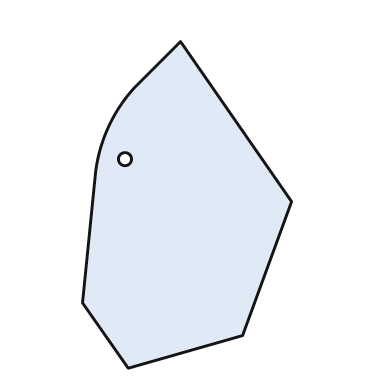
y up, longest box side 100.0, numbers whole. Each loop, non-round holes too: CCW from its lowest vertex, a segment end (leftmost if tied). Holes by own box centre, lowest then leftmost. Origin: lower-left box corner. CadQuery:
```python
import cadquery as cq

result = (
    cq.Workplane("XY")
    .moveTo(14.0, 0.0)
    .lineTo(49.0, 10.0)
    .lineTo(64.0, 51.0)
    .lineTo(30.0, 100.0)
    .lineTo(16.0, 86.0)
    .threePointArc((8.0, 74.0), (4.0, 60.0))
    .lineTo(0.0, 20.0)
    .close()
    .moveTo(13.0, 64.0)
    .circle(2.0)
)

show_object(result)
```